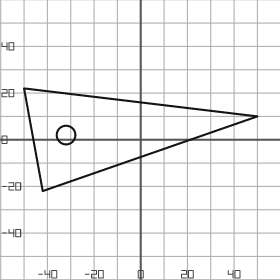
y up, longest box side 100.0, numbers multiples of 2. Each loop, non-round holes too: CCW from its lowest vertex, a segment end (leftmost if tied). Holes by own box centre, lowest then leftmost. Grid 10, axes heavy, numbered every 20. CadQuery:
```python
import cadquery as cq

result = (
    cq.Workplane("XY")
    .moveTo(-42.0, -22.0)
    .lineTo(50.0, 10.0)
    .lineTo(-50.0, 22.0)
    .close()
    .moveTo(-32.0, 2.0)
    .circle(4.0)
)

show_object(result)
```